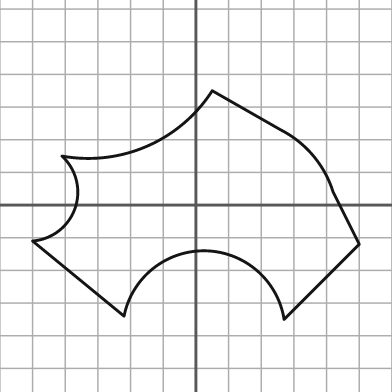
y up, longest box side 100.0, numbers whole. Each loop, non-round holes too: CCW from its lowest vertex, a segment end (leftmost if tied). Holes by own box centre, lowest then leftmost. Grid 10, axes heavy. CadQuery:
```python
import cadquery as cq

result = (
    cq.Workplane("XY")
    .moveTo(27.0, -35.0)
    .lineTo(50.0, -12.0)
    .lineTo(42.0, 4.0)
    .threePointArc((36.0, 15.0), (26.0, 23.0))
    .lineTo(5.0, 35.0)
    .threePointArc((-15.0, 18.0), (-41.0, 15.0))
    .threePointArc((-37.0, -1.0), (-50.0, -11.0))
    .lineTo(-22.0, -34.0)
    .threePointArc((3.0, -14.0), (27.0, -35.0))
    .close()
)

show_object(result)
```